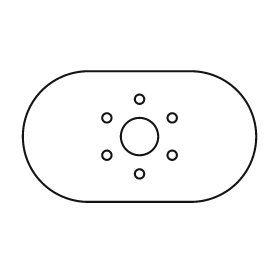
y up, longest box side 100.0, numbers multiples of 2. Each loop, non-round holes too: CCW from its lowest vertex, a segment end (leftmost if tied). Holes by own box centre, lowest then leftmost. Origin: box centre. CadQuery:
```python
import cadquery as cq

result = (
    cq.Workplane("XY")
    .moveTo(-22.0, -28.0)
    .lineTo(22.0, -28.0)
    .threePointArc((50.0, 0.0), (22.0, 28.0))
    .lineTo(-22.0, 28.0)
    .threePointArc((-50.0, 0.0), (-22.0, -28.0))
    .close()
    .moveTo(0.0, -16.0)
    .circle(2.0)
    .moveTo(-14.0, -8.0)
    .circle(2.0)
    .moveTo(14.0, -8.0)
    .circle(2.0)
    .moveTo(0.0, 0.0)
    .circle(8.0)
    .moveTo(-14.0, 8.0)
    .circle(2.0)
    .moveTo(14.0, 8.0)
    .circle(2.0)
    .moveTo(0.0, 16.0)
    .circle(2.0)
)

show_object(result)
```